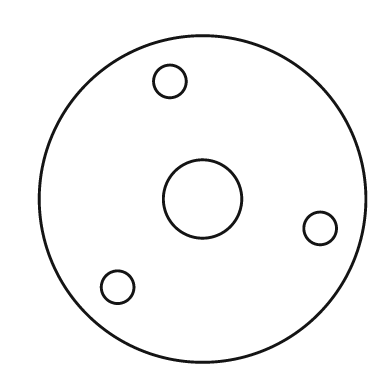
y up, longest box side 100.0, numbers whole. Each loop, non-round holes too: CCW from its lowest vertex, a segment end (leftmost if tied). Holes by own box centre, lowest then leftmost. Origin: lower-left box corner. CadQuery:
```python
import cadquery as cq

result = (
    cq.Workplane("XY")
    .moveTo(50.0, 50.0)
    .circle(50.0)
    .moveTo(24.0, 23.0)
    .circle(5.0)
    .moveTo(86.0, 41.0)
    .circle(5.0)
    .moveTo(50.0, 50.0)
    .circle(12.0)
    .moveTo(40.0, 86.0)
    .circle(5.0)
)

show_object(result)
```